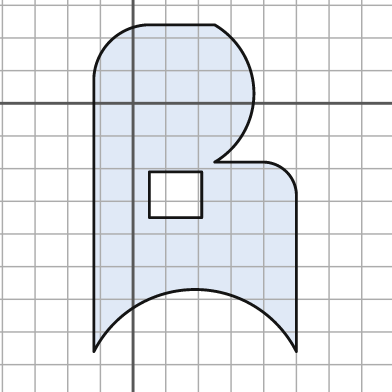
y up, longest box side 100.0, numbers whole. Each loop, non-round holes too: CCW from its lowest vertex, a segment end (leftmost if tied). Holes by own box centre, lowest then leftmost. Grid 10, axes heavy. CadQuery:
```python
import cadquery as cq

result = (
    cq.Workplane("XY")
    .moveTo(-12.0, -76.0)
    .threePointArc((19.0, -57.0), (50.0, -76.0))
    .lineTo(50.0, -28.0)
    .threePointArc((47.0, -21.0), (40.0, -18.0))
    .lineTo(25.0, -18.0)
    .threePointArc((37.0, 3.0), (25.0, 24.0))
    .lineTo(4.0, 24.0)
    .threePointArc((-7.0, 19.0), (-12.0, 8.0))
    .close()
    .moveTo(5.0, -35.0)
    .lineTo(21.0, -35.0)
    .lineTo(21.0, -21.0)
    .lineTo(5.0, -21.0)
    .close()
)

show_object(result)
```